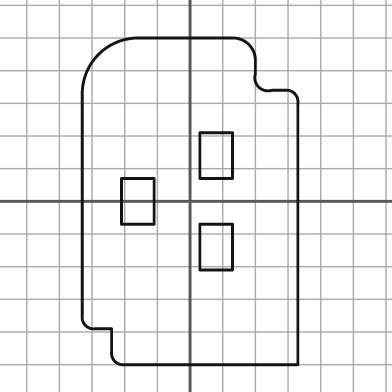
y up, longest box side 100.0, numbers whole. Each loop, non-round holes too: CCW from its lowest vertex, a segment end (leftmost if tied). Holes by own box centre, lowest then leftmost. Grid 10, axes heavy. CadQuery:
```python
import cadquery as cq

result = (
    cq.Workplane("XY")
    .moveTo(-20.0, -50.0)
    .lineTo(33.0, -50.0)
    .lineTo(33.0, 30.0)
    .threePointArc((32.0, 33.0), (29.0, 34.0))
    .lineTo(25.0, 34.0)
    .threePointArc((21.0, 35.0), (20.0, 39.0))
    .lineTo(20.0, 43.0)
    .threePointArc((18.0, 48.0), (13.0, 50.0))
    .lineTo(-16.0, 50.0)
    .threePointArc((-28.0, 45.0), (-33.0, 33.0))
    .lineTo(-33.0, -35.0)
    .threePointArc((-32.0, -38.0), (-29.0, -39.0))
    .lineTo(-24.0, -39.0)
    .lineTo(-24.0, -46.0)
    .threePointArc((-23.0, -49.0), (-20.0, -50.0))
    .close()
    .moveTo(3.0, -21.0)
    .lineTo(13.0, -21.0)
    .lineTo(13.0, -7.0)
    .lineTo(3.0, -7.0)
    .close()
    .moveTo(-21.0, -7.0)
    .lineTo(-11.0, -7.0)
    .lineTo(-11.0, 7.0)
    .lineTo(-21.0, 7.0)
    .close()
    .moveTo(3.0, 7.0)
    .lineTo(13.0, 7.0)
    .lineTo(13.0, 21.0)
    .lineTo(3.0, 21.0)
    .close()
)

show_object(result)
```